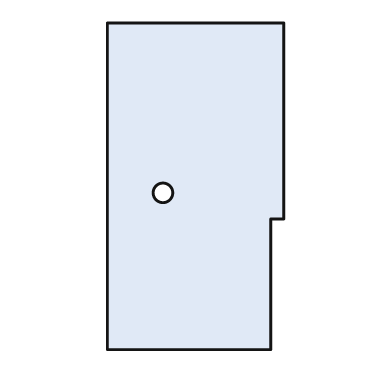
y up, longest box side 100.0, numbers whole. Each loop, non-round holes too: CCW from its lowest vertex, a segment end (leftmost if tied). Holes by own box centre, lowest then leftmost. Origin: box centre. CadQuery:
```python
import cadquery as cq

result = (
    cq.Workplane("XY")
    .moveTo(-27.0, -50.0)
    .lineTo(23.0, -50.0)
    .lineTo(23.0, -10.0)
    .lineTo(27.0, -10.0)
    .lineTo(27.0, 50.0)
    .lineTo(-27.0, 50.0)
    .close()
    .moveTo(-10.0, -2.0)
    .circle(3.0)
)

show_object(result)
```